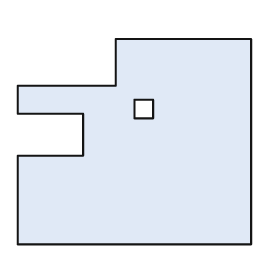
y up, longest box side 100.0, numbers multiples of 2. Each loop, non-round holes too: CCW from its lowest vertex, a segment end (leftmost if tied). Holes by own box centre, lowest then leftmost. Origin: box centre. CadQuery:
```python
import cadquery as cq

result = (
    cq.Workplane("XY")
    .moveTo(-50.0, -44.0)
    .lineTo(50.0, -44.0)
    .lineTo(50.0, 44.0)
    .lineTo(-8.0, 44.0)
    .lineTo(-8.0, 24.0)
    .lineTo(-50.0, 24.0)
    .lineTo(-50.0, 12.0)
    .lineTo(-22.0, 12.0)
    .lineTo(-22.0, -6.0)
    .lineTo(-50.0, -6.0)
    .close()
    .moveTo(0.0, 10.0)
    .lineTo(8.0, 10.0)
    .lineTo(8.0, 18.0)
    .lineTo(0.0, 18.0)
    .close()
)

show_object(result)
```